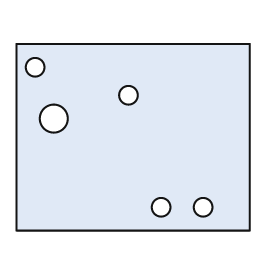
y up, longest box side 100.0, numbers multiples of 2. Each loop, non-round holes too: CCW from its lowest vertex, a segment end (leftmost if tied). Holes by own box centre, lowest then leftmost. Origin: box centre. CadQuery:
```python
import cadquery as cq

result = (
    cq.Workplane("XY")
    .moveTo(-50.0, -40.0)
    .lineTo(50.0, -40.0)
    .lineTo(50.0, 40.0)
    .lineTo(-50.0, 40.0)
    .close()
    .moveTo(12.0, -30.0)
    .circle(4.0)
    .moveTo(30.0, -30.0)
    .circle(4.0)
    .moveTo(-34.0, 8.0)
    .circle(6.0)
    .moveTo(-2.0, 18.0)
    .circle(4.0)
    .moveTo(-42.0, 30.0)
    .circle(4.0)
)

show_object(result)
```